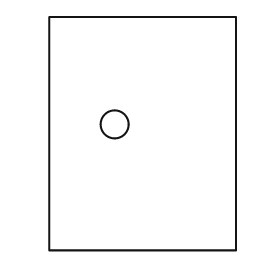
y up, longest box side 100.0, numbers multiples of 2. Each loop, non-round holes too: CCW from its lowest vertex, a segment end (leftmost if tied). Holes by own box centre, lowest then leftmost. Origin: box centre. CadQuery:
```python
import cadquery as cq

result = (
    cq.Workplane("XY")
    .moveTo(-40.0, -50.0)
    .lineTo(40.0, -50.0)
    .lineTo(40.0, 50.0)
    .lineTo(-40.0, 50.0)
    .close()
    .moveTo(-12.0, 4.0)
    .circle(6.0)
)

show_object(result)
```